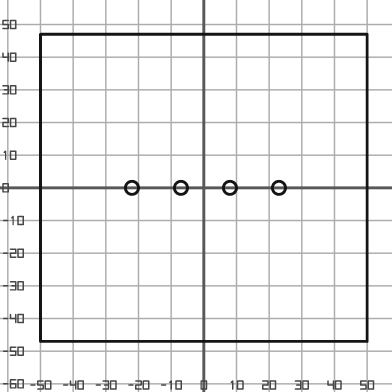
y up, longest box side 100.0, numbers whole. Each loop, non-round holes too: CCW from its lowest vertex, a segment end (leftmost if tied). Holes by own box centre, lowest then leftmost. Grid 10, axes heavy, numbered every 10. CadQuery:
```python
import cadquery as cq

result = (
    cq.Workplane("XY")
    .moveTo(-50.0, -47.0)
    .lineTo(50.0, -47.0)
    .lineTo(50.0, 47.0)
    .lineTo(-50.0, 47.0)
    .close()
    .moveTo(-22.0, 0.0)
    .circle(2.0)
    .moveTo(-7.0, 0.0)
    .circle(2.0)
    .moveTo(8.0, 0.0)
    .circle(2.0)
    .moveTo(23.0, 0.0)
    .circle(2.0)
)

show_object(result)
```